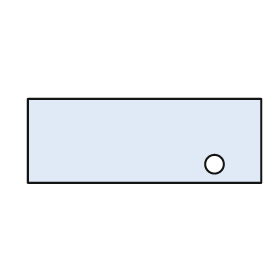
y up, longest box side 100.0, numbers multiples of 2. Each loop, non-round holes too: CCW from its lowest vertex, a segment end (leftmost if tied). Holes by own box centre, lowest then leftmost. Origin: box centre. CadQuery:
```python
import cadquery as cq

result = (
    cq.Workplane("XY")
    .moveTo(-50.0, -18.0)
    .lineTo(50.0, -18.0)
    .lineTo(50.0, 18.0)
    .lineTo(-50.0, 18.0)
    .close()
    .moveTo(30.0, -10.0)
    .circle(4.0)
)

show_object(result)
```